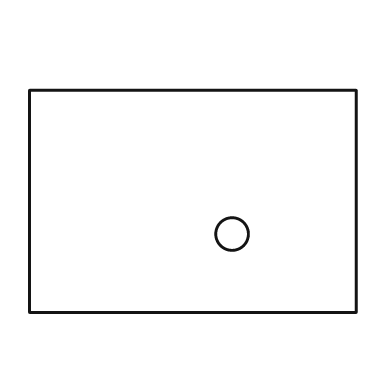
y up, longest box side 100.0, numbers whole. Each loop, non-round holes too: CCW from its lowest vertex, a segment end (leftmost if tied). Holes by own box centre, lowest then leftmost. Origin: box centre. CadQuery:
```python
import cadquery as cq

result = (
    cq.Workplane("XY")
    .moveTo(-50.0, -34.0)
    .lineTo(50.0, -34.0)
    .lineTo(50.0, 34.0)
    .lineTo(-50.0, 34.0)
    .close()
    .moveTo(12.0, -10.0)
    .circle(5.0)
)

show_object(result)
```